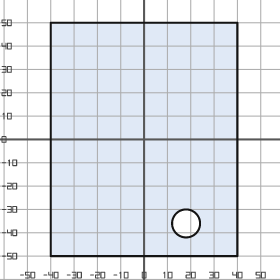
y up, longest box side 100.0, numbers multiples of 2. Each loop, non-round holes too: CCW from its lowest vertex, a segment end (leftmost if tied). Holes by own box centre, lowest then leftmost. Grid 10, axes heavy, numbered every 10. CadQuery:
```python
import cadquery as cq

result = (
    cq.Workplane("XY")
    .moveTo(-40.0, -50.0)
    .lineTo(40.0, -50.0)
    .lineTo(40.0, 50.0)
    .lineTo(-40.0, 50.0)
    .close()
    .moveTo(18.0, -36.0)
    .circle(6.0)
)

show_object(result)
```